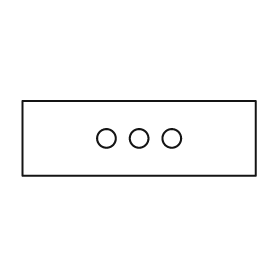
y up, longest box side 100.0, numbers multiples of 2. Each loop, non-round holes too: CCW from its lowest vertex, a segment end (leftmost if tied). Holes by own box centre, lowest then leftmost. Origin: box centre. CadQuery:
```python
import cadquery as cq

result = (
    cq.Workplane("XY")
    .moveTo(-50.0, -16.0)
    .lineTo(50.0, -16.0)
    .lineTo(50.0, 16.0)
    .lineTo(-50.0, 16.0)
    .close()
    .moveTo(-14.0, 0.0)
    .circle(4.0)
    .moveTo(0.0, 0.0)
    .circle(4.0)
    .moveTo(14.0, 0.0)
    .circle(4.0)
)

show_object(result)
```